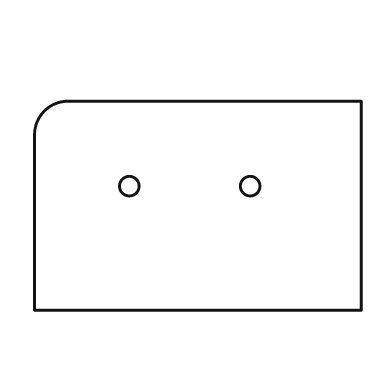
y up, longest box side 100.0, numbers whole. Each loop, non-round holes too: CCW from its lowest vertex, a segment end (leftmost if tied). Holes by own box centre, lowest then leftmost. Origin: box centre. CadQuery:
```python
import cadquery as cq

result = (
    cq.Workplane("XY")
    .moveTo(-50.0, -32.0)
    .lineTo(50.0, -32.0)
    .lineTo(50.0, 32.0)
    .lineTo(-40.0, 32.0)
    .threePointArc((-47.0, 29.0), (-50.0, 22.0))
    .close()
    .moveTo(-21.0, 6.0)
    .circle(3.0)
    .moveTo(16.0, 6.0)
    .circle(3.0)
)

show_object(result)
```